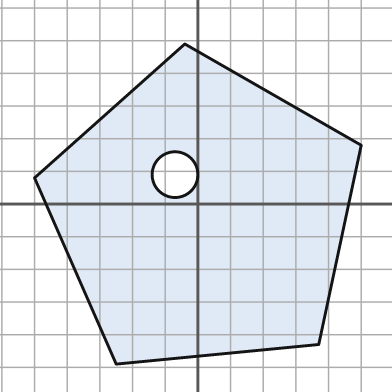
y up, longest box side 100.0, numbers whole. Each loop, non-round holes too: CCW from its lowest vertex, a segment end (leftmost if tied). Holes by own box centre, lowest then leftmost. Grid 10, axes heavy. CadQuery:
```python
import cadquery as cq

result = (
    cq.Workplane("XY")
    .moveTo(-25.0, -49.0)
    .lineTo(37.0, -43.0)
    .lineTo(50.0, 18.0)
    .lineTo(-4.0, 49.0)
    .lineTo(-50.0, 8.0)
    .close()
    .moveTo(-7.0, 9.0)
    .circle(7.0)
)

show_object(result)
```